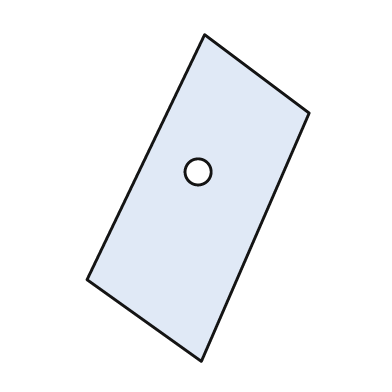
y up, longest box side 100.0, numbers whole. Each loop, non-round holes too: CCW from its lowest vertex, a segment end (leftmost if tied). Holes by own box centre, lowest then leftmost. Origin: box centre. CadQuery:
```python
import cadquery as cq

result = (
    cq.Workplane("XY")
    .moveTo(1.0, -50.0)
    .lineTo(34.0, 26.0)
    .lineTo(2.0, 50.0)
    .lineTo(-34.0, -25.0)
    .close()
    .moveTo(0.0, 8.0)
    .circle(4.0)
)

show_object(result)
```